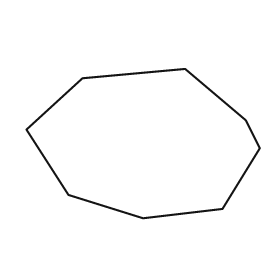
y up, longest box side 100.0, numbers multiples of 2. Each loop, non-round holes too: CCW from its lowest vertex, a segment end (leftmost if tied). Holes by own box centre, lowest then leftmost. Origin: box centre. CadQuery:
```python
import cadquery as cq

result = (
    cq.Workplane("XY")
    .moveTo(0.0, -32.0)
    .lineTo(34.0, -28.0)
    .lineTo(50.0, -2.0)
    .lineTo(44.0, 10.0)
    .lineTo(18.0, 32.0)
    .lineTo(-26.0, 28.0)
    .lineTo(-50.0, 6.0)
    .lineTo(-32.0, -22.0)
    .close()
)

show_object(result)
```